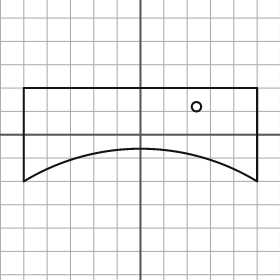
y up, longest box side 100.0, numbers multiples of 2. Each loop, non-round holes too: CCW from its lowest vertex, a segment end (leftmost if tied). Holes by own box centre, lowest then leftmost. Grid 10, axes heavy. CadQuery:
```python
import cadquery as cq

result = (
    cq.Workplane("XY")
    .moveTo(-50.0, -20.0)
    .threePointArc((0.0, -6.0), (50.0, -20.0))
    .lineTo(50.0, 20.0)
    .lineTo(-50.0, 20.0)
    .close()
    .moveTo(24.0, 12.0)
    .circle(2.0)
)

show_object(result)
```